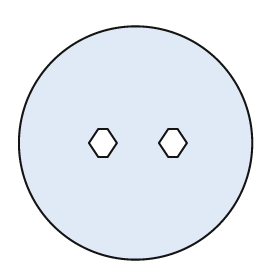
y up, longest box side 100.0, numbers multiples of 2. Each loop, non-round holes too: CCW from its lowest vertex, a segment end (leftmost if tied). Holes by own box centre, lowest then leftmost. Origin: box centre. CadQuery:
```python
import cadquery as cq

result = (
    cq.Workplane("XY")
    .moveTo(0.0, 0.0)
    .circle(50.0)
    .moveTo(-16.0, -6.0)
    .lineTo(-12.0, -6.0)
    .lineTo(-8.0, 0.0)
    .lineTo(-12.0, 6.0)
    .lineTo(-16.0, 6.0)
    .lineTo(-20.0, 0.0)
    .close()
    .moveTo(14.0, -6.0)
    .lineTo(18.0, -6.0)
    .lineTo(22.0, 0.0)
    .lineTo(18.0, 6.0)
    .lineTo(14.0, 6.0)
    .lineTo(10.0, 0.0)
    .close()
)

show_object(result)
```